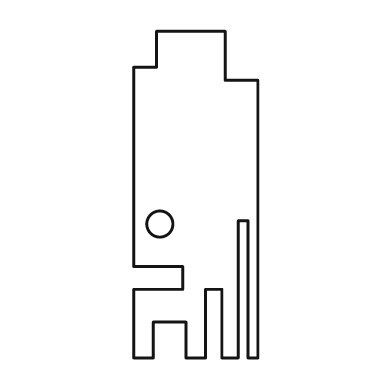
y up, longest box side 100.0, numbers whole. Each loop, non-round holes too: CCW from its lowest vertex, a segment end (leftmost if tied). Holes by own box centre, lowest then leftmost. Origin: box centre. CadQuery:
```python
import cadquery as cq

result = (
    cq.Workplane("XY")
    .moveTo(-19.0, -50.0)
    .lineTo(-13.0, -50.0)
    .lineTo(-13.0, -39.0)
    .lineTo(-3.0, -39.0)
    .lineTo(-3.0, -50.0)
    .lineTo(3.0, -50.0)
    .lineTo(3.0, -29.0)
    .lineTo(8.0, -29.0)
    .lineTo(8.0, -50.0)
    .lineTo(13.0, -50.0)
    .lineTo(13.0, -8.0)
    .lineTo(16.0, -8.0)
    .lineTo(16.0, -50.0)
    .lineTo(19.0, -50.0)
    .lineTo(19.0, 35.0)
    .lineTo(9.0, 35.0)
    .lineTo(9.0, 50.0)
    .lineTo(-12.0, 50.0)
    .lineTo(-12.0, 39.0)
    .lineTo(-19.0, 39.0)
    .lineTo(-19.0, -22.0)
    .lineTo(-4.0, -22.0)
    .lineTo(-4.0, -29.0)
    .lineTo(-19.0, -29.0)
    .close()
    .moveTo(-11.0, -9.0)
    .circle(4.0)
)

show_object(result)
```